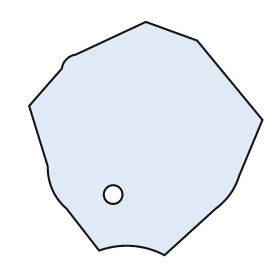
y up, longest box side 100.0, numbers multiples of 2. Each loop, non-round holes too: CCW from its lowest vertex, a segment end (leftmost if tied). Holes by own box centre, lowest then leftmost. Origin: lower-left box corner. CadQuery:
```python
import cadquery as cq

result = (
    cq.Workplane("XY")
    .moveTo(58.0, 0.0)
    .lineTo(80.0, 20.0)
    .threePointArc((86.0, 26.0), (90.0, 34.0))
    .lineTo(100.0, 58.0)
    .lineTo(72.0, 92.0)
    .lineTo(50.0, 100.0)
    .lineTo(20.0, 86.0)
    .threePointArc((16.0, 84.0), (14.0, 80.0))
    .lineTo(0.0, 64.0)
    .lineTo(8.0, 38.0)
    .threePointArc((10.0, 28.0), (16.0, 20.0))
    .lineTo(30.0, 2.0)
    .threePointArc((44.0, 4.0), (58.0, 0.0))
    .close()
    .moveTo(36.0, 26.0)
    .circle(4.0)
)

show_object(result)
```